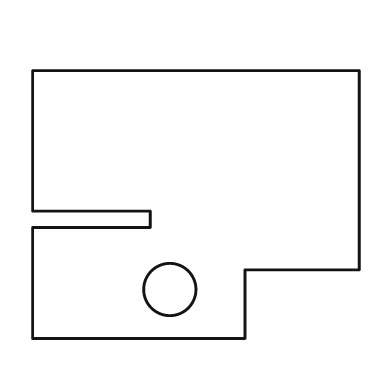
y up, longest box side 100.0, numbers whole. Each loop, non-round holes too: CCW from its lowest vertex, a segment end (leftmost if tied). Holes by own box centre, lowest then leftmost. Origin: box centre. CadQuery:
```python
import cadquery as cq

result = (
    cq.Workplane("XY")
    .moveTo(-50.0, -41.0)
    .lineTo(15.0, -41.0)
    .lineTo(15.0, -20.0)
    .lineTo(50.0, -20.0)
    .lineTo(50.0, 41.0)
    .lineTo(-50.0, 41.0)
    .lineTo(-50.0, -2.0)
    .lineTo(-14.0, -2.0)
    .lineTo(-14.0, -7.0)
    .lineTo(-50.0, -7.0)
    .close()
    .moveTo(-8.0, -26.0)
    .circle(8.0)
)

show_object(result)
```